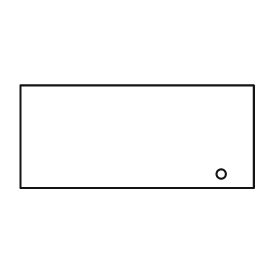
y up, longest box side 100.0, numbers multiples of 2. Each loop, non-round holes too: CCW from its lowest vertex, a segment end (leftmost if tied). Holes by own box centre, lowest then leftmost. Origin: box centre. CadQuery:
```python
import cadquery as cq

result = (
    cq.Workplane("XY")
    .moveTo(-50.0, -22.0)
    .lineTo(50.0, -22.0)
    .lineTo(50.0, 22.0)
    .lineTo(-50.0, 22.0)
    .close()
    .moveTo(36.0, -16.0)
    .circle(2.0)
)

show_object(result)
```